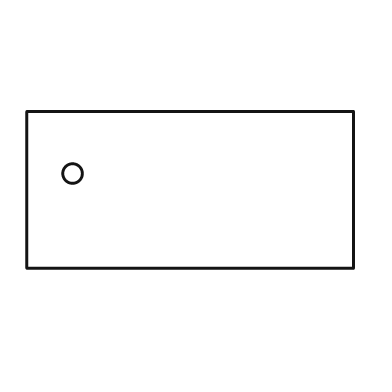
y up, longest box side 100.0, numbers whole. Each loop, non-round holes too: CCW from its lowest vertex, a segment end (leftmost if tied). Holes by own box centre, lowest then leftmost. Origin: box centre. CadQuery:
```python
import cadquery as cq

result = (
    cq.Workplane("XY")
    .moveTo(-50.0, -24.0)
    .lineTo(50.0, -24.0)
    .lineTo(50.0, 24.0)
    .lineTo(-50.0, 24.0)
    .close()
    .moveTo(-36.0, 5.0)
    .circle(3.0)
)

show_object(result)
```